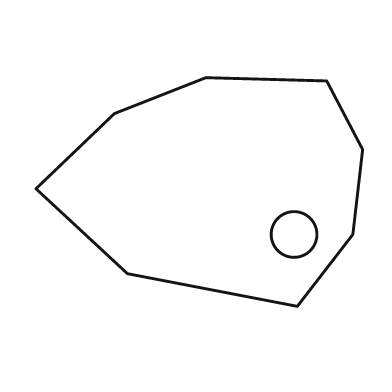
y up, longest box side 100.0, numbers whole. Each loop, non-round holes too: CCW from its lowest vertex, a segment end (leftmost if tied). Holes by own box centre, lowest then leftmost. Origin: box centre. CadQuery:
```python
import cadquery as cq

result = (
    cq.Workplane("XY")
    .moveTo(30.0, -35.0)
    .lineTo(47.0, -13.0)
    .lineTo(50.0, 13.0)
    .lineTo(39.0, 34.0)
    .lineTo(2.0, 35.0)
    .lineTo(-26.0, 24.0)
    .lineTo(-50.0, 1.0)
    .lineTo(-22.0, -25.0)
    .close()
    .moveTo(29.0, -13.0)
    .circle(7.0)
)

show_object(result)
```